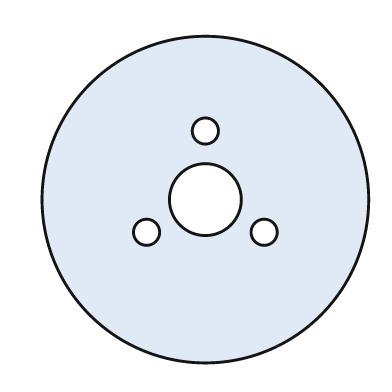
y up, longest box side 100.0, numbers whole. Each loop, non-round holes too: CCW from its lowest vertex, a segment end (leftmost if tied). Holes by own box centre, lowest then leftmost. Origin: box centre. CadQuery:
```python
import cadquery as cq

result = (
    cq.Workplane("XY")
    .moveTo(0.0, 0.0)
    .circle(50.0)
    .moveTo(-18.0, -10.0)
    .circle(4.0)
    .moveTo(18.0, -10.0)
    .circle(4.0)
    .moveTo(0.0, 0.0)
    .circle(11.0)
    .moveTo(0.0, 21.0)
    .circle(4.0)
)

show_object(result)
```